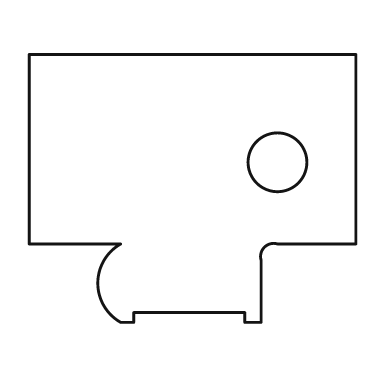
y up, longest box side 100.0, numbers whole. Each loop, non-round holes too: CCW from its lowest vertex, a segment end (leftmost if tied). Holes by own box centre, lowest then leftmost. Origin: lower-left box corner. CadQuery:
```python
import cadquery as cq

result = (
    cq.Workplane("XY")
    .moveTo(28.0, 0.0)
    .lineTo(32.0, 0.0)
    .lineTo(32.0, 3.0)
    .lineTo(66.0, 3.0)
    .lineTo(66.0, 0.0)
    .lineTo(71.0, 0.0)
    .lineTo(71.0, 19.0)
    .threePointArc((72.0, 23.0), (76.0, 24.0))
    .lineTo(100.0, 24.0)
    .lineTo(100.0, 82.0)
    .lineTo(0.0, 82.0)
    .lineTo(0.0, 24.0)
    .lineTo(28.0, 24.0)
    .threePointArc((21.0, 12.0), (28.0, 0.0))
    .close()
    .moveTo(76.0, 49.0)
    .circle(9.0)
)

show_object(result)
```